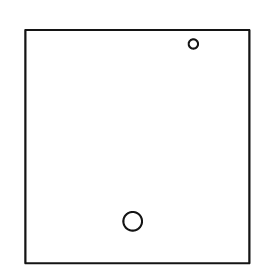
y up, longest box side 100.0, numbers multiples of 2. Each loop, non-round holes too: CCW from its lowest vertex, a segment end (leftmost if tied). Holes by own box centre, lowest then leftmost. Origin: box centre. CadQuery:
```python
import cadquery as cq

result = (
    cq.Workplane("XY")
    .moveTo(-48.0, -50.0)
    .lineTo(48.0, -50.0)
    .lineTo(48.0, 50.0)
    .lineTo(-48.0, 50.0)
    .close()
    .moveTo(-2.0, -32.0)
    .circle(4.0)
    .moveTo(24.0, 44.0)
    .circle(2.0)
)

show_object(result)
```